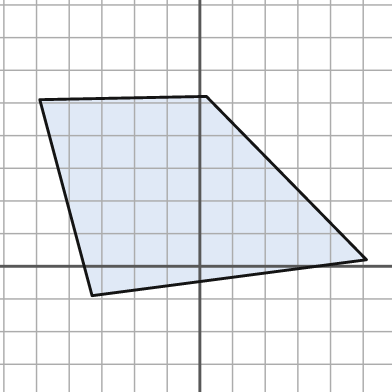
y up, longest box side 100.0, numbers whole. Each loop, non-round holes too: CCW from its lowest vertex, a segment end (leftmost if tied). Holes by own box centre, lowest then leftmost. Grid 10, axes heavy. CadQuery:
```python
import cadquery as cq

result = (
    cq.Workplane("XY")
    .moveTo(-33.0, -9.0)
    .lineTo(51.0, 2.0)
    .lineTo(2.0, 52.0)
    .lineTo(-49.0, 51.0)
    .close()
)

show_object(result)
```